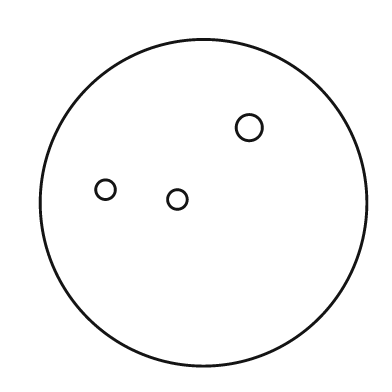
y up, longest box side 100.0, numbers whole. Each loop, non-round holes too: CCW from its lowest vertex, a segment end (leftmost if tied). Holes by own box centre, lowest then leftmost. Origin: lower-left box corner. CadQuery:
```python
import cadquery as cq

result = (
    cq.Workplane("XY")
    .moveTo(50.0, 50.0)
    .circle(50.0)
    .moveTo(42.0, 51.0)
    .circle(3.0)
    .moveTo(20.0, 54.0)
    .circle(3.0)
    .moveTo(64.0, 73.0)
    .circle(4.0)
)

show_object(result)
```